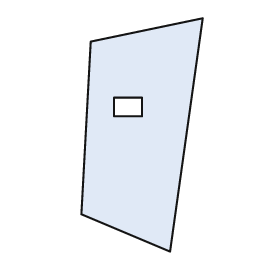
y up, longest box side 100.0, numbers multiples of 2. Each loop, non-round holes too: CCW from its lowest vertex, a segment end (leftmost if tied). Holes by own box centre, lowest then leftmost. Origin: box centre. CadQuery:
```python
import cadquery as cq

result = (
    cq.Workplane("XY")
    .moveTo(12.0, -50.0)
    .lineTo(26.0, 50.0)
    .lineTo(-22.0, 40.0)
    .lineTo(-26.0, -34.0)
    .close()
    .moveTo(-12.0, 8.0)
    .lineTo(0.0, 8.0)
    .lineTo(0.0, 16.0)
    .lineTo(-12.0, 16.0)
    .close()
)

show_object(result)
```